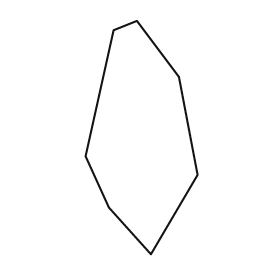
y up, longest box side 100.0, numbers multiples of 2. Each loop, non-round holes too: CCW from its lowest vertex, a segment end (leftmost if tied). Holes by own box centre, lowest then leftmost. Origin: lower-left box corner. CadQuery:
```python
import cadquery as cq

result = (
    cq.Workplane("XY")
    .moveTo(28.0, 0.0)
    .lineTo(48.0, 34.0)
    .lineTo(40.0, 76.0)
    .lineTo(22.0, 100.0)
    .lineTo(12.0, 96.0)
    .lineTo(0.0, 42.0)
    .lineTo(10.0, 20.0)
    .close()
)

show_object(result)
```